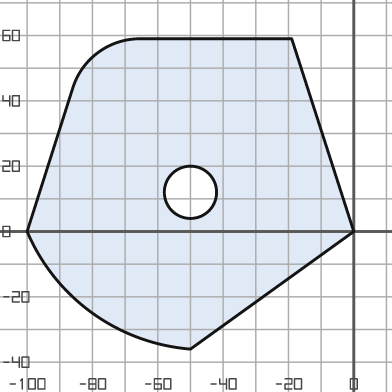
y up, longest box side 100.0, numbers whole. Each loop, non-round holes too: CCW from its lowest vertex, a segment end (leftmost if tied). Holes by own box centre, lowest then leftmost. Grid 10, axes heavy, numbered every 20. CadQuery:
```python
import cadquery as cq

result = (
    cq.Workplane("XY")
    .moveTo(-50.0, -36.0)
    .lineTo(0.0, 0.0)
    .lineTo(-19.0, 59.0)
    .lineTo(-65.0, 59.0)
    .threePointArc((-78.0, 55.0), (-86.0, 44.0))
    .lineTo(-100.0, 0.0)
    .threePointArc((-80.0, -25.0), (-50.0, -36.0))
    .close()
    .moveTo(-50.0, 12.0)
    .circle(8.0)
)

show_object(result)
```